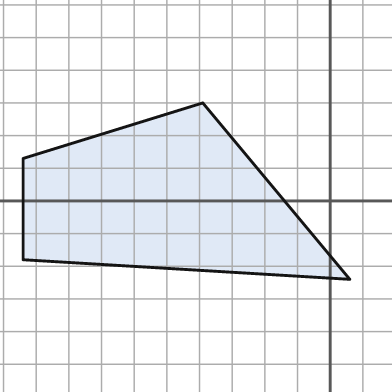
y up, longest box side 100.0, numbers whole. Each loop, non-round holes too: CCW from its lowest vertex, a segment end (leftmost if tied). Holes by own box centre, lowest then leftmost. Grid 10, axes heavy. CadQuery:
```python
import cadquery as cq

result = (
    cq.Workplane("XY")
    .moveTo(6.0, -24.0)
    .lineTo(-39.0, 30.0)
    .lineTo(-94.0, 13.0)
    .lineTo(-94.0, -18.0)
    .close()
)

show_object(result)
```